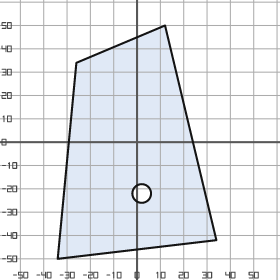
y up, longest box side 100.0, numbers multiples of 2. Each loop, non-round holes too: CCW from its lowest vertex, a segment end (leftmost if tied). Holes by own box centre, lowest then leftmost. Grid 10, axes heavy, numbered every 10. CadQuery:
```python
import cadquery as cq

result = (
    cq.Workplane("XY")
    .moveTo(-34.0, -50.0)
    .lineTo(34.0, -42.0)
    .lineTo(12.0, 50.0)
    .lineTo(-26.0, 34.0)
    .close()
    .moveTo(2.0, -22.0)
    .circle(4.0)
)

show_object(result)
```